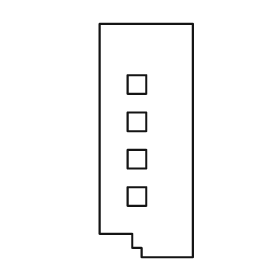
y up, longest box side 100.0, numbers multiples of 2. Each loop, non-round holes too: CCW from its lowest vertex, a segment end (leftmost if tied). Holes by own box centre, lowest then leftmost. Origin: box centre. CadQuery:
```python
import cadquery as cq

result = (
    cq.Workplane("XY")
    .moveTo(-2.0, -50.0)
    .lineTo(20.0, -50.0)
    .lineTo(20.0, 50.0)
    .lineTo(-20.0, 50.0)
    .lineTo(-20.0, -40.0)
    .lineTo(-6.0, -40.0)
    .lineTo(-6.0, -46.0)
    .lineTo(-2.0, -46.0)
    .close()
    .moveTo(-8.0, -28.0)
    .lineTo(0.0, -28.0)
    .lineTo(0.0, -20.0)
    .lineTo(-8.0, -20.0)
    .close()
    .moveTo(-8.0, -12.0)
    .lineTo(0.0, -12.0)
    .lineTo(0.0, -4.0)
    .lineTo(-8.0, -4.0)
    .close()
    .moveTo(-8.0, 4.0)
    .lineTo(0.0, 4.0)
    .lineTo(0.0, 12.0)
    .lineTo(-8.0, 12.0)
    .close()
    .moveTo(-8.0, 20.0)
    .lineTo(0.0, 20.0)
    .lineTo(0.0, 28.0)
    .lineTo(-8.0, 28.0)
    .close()
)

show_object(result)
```